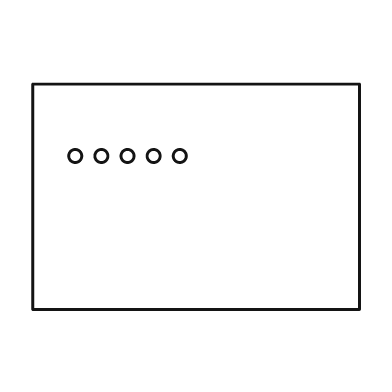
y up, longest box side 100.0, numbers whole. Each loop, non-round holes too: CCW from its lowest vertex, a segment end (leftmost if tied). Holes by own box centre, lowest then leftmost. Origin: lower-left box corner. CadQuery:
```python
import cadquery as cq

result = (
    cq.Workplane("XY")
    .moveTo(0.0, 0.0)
    .lineTo(100.0, 0.0)
    .lineTo(100.0, 69.0)
    .lineTo(0.0, 69.0)
    .close()
    .moveTo(13.0, 47.0)
    .circle(2.0)
    .moveTo(21.0, 47.0)
    .circle(2.0)
    .moveTo(29.0, 47.0)
    .circle(2.0)
    .moveTo(37.0, 47.0)
    .circle(2.0)
    .moveTo(45.0, 47.0)
    .circle(2.0)
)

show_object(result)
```